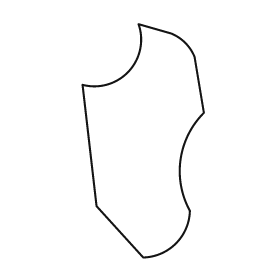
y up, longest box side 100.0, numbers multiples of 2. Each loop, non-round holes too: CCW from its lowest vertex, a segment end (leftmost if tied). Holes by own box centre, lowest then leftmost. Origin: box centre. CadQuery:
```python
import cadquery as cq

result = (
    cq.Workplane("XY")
    .moveTo(0.0, -50.0)
    .threePointArc((14.0, -44.0), (20.0, -30.0))
    .threePointArc((16.0, -8.0), (26.0, 12.0))
    .lineTo(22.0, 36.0)
    .threePointArc((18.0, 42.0), (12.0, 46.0))
    .lineTo(-2.0, 50.0)
    .threePointArc((-6.0, 30.0), (-26.0, 24.0))
    .lineTo(-20.0, -28.0)
    .close()
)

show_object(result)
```